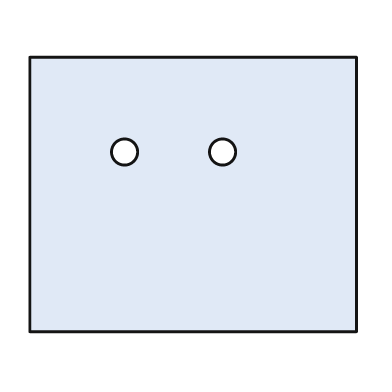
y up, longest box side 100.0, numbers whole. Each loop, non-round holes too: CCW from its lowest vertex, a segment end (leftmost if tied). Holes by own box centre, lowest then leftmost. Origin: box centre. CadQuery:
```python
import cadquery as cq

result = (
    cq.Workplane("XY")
    .moveTo(-50.0, -42.0)
    .lineTo(50.0, -42.0)
    .lineTo(50.0, 42.0)
    .lineTo(-50.0, 42.0)
    .close()
    .moveTo(-21.0, 13.0)
    .circle(4.0)
    .moveTo(9.0, 13.0)
    .circle(4.0)
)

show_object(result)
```